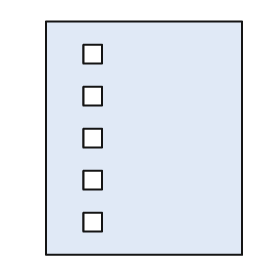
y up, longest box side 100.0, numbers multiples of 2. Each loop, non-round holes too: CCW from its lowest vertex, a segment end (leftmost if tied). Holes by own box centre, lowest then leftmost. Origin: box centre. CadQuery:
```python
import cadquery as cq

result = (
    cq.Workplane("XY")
    .moveTo(-42.0, -50.0)
    .lineTo(42.0, -50.0)
    .lineTo(42.0, 50.0)
    .lineTo(-42.0, 50.0)
    .close()
    .moveTo(-26.0, -40.0)
    .lineTo(-18.0, -40.0)
    .lineTo(-18.0, -32.0)
    .lineTo(-26.0, -32.0)
    .close()
    .moveTo(-26.0, -22.0)
    .lineTo(-18.0, -22.0)
    .lineTo(-18.0, -14.0)
    .lineTo(-26.0, -14.0)
    .close()
    .moveTo(-26.0, -4.0)
    .lineTo(-18.0, -4.0)
    .lineTo(-18.0, 4.0)
    .lineTo(-26.0, 4.0)
    .close()
    .moveTo(-26.0, 14.0)
    .lineTo(-18.0, 14.0)
    .lineTo(-18.0, 22.0)
    .lineTo(-26.0, 22.0)
    .close()
    .moveTo(-26.0, 32.0)
    .lineTo(-18.0, 32.0)
    .lineTo(-18.0, 40.0)
    .lineTo(-26.0, 40.0)
    .close()
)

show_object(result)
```